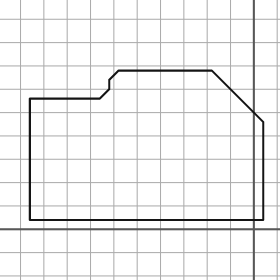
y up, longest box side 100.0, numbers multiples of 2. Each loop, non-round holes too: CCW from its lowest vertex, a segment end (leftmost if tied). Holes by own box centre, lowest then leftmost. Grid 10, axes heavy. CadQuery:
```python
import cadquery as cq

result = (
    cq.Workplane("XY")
    .moveTo(-96.0, 4.0)
    .lineTo(4.0, 4.0)
    .lineTo(4.0, 46.0)
    .lineTo(-18.0, 68.0)
    .lineTo(-58.0, 68.0)
    .lineTo(-62.0, 64.0)
    .lineTo(-62.0, 60.0)
    .lineTo(-66.0, 56.0)
    .lineTo(-96.0, 56.0)
    .close()
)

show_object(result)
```